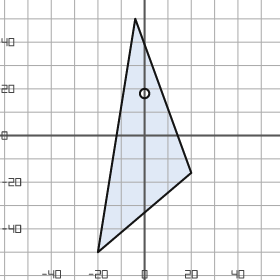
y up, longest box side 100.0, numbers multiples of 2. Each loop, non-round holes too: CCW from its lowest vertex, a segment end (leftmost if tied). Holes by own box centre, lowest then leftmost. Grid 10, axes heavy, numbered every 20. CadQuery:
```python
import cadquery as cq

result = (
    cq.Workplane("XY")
    .moveTo(-20.0, -50.0)
    .lineTo(20.0, -16.0)
    .lineTo(-4.0, 50.0)
    .close()
    .moveTo(0.0, 18.0)
    .circle(2.0)
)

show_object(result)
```